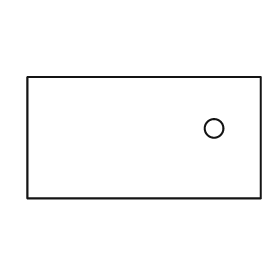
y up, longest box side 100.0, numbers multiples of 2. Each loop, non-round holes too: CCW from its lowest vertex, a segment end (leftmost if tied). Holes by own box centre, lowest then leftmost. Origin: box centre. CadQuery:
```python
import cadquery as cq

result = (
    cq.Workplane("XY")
    .moveTo(-50.0, -26.0)
    .lineTo(50.0, -26.0)
    .lineTo(50.0, 26.0)
    .lineTo(-50.0, 26.0)
    .close()
    .moveTo(30.0, 4.0)
    .circle(4.0)
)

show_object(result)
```